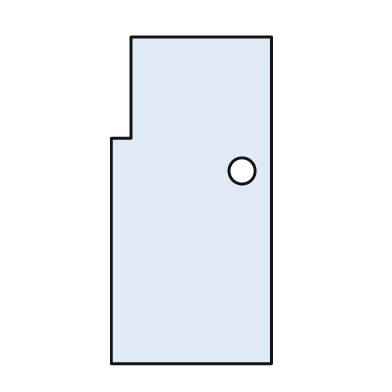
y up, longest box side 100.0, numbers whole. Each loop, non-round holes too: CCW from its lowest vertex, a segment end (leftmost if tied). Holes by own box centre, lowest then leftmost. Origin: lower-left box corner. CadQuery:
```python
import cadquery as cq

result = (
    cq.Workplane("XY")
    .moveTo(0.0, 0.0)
    .lineTo(49.0, 0.0)
    .lineTo(49.0, 100.0)
    .lineTo(6.0, 100.0)
    .lineTo(6.0, 69.0)
    .lineTo(0.0, 69.0)
    .close()
    .moveTo(40.0, 59.0)
    .circle(4.0)
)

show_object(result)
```